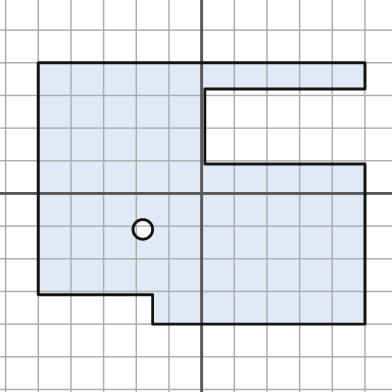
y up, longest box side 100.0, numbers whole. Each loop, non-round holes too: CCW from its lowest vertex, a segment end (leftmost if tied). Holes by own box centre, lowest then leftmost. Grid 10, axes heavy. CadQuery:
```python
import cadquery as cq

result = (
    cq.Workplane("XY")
    .moveTo(-15.0, -40.0)
    .lineTo(50.0, -40.0)
    .lineTo(50.0, 9.0)
    .lineTo(1.0, 9.0)
    .lineTo(1.0, 32.0)
    .lineTo(50.0, 32.0)
    .lineTo(50.0, 40.0)
    .lineTo(-50.0, 40.0)
    .lineTo(-50.0, -31.0)
    .lineTo(-15.0, -31.0)
    .close()
    .moveTo(-18.0, -11.0)
    .circle(3.0)
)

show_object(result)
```